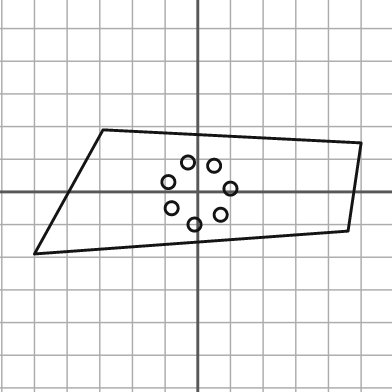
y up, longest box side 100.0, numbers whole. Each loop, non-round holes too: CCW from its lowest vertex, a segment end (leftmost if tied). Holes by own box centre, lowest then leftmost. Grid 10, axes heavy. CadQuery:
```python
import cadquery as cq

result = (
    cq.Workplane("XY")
    .moveTo(-50.0, -19.0)
    .lineTo(46.0, -12.0)
    .lineTo(50.0, 15.0)
    .lineTo(-29.0, 19.0)
    .close()
    .moveTo(-1.0, -10.0)
    .circle(2.0)
    .moveTo(7.0, -7.0)
    .circle(2.0)
    .moveTo(-8.0, -5.0)
    .circle(2.0)
    .moveTo(10.0, 1.0)
    .circle(2.0)
    .moveTo(-9.0, 3.0)
    .circle(2.0)
    .moveTo(5.0, 8.0)
    .circle(2.0)
    .moveTo(-3.0, 9.0)
    .circle(2.0)
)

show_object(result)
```